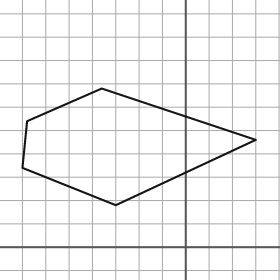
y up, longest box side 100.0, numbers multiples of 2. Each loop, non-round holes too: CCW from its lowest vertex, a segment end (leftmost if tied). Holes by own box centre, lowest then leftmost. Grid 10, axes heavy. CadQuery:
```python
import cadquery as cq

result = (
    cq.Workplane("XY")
    .moveTo(-30.0, 18.0)
    .lineTo(30.0, 46.0)
    .lineTo(-36.0, 68.0)
    .lineTo(-68.0, 54.0)
    .lineTo(-70.0, 34.0)
    .close()
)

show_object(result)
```